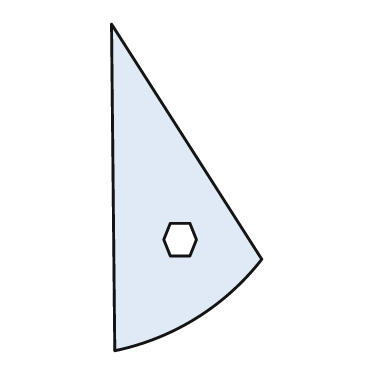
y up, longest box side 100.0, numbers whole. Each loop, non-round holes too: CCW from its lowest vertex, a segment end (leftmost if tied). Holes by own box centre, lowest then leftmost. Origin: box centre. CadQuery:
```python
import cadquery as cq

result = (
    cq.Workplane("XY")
    .moveTo(-22.0, -50.0)
    .threePointArc((3.0, -40.0), (23.0, -22.0))
    .lineTo(-23.0, 50.0)
    .close()
    .moveTo(-5.0, -21.0)
    .lineTo(1.0, -21.0)
    .lineTo(3.0, -16.0)
    .lineTo(1.0, -11.0)
    .lineTo(-5.0, -11.0)
    .lineTo(-7.0, -16.0)
    .close()
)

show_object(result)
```